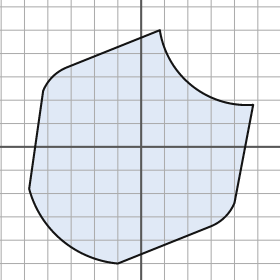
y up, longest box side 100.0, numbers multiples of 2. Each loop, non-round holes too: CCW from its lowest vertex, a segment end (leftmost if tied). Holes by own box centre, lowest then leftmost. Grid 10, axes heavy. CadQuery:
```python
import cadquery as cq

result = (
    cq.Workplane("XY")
    .moveTo(-10.0, -50.0)
    .lineTo(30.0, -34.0)
    .threePointArc((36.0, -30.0), (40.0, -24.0))
    .lineTo(48.0, 18.0)
    .threePointArc((22.0, 26.0), (8.0, 50.0))
    .lineTo(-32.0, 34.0)
    .threePointArc((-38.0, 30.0), (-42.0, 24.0))
    .lineTo(-48.0, -18.0)
    .threePointArc((-34.0, -40.0), (-10.0, -50.0))
    .close()
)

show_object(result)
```